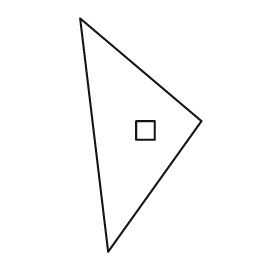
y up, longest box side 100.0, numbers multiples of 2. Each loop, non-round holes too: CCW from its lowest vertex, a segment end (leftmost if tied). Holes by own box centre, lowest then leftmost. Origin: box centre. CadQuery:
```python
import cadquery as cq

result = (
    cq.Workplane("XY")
    .moveTo(-14.0, -50.0)
    .lineTo(26.0, 6.0)
    .lineTo(-26.0, 50.0)
    .close()
    .moveTo(-2.0, -2.0)
    .lineTo(6.0, -2.0)
    .lineTo(6.0, 6.0)
    .lineTo(-2.0, 6.0)
    .close()
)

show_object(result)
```